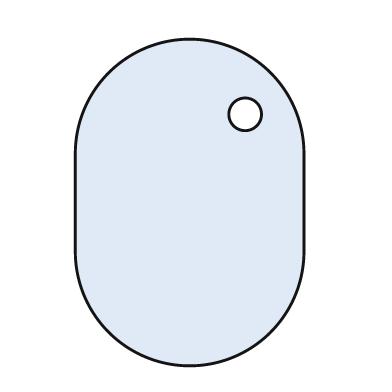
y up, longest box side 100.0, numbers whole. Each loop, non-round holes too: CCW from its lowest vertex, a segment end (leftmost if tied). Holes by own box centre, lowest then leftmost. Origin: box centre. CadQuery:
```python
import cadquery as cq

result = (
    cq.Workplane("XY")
    .moveTo(-35.0, -15.0)
    .threePointArc((0.0, -50.0), (35.0, -15.0))
    .lineTo(35.0, 15.0)
    .threePointArc((0.0, 50.0), (-35.0, 15.0))
    .close()
    .moveTo(17.0, 27.0)
    .circle(5.0)
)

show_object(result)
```